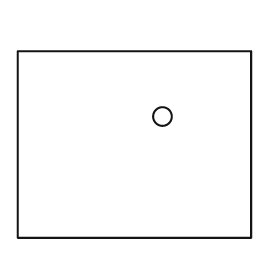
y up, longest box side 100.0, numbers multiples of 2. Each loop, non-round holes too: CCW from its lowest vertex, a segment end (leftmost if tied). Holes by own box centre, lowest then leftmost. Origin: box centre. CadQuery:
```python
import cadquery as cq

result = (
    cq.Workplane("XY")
    .moveTo(-50.0, -40.0)
    .lineTo(50.0, -40.0)
    .lineTo(50.0, 40.0)
    .lineTo(-50.0, 40.0)
    .close()
    .moveTo(12.0, 12.0)
    .circle(4.0)
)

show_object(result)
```